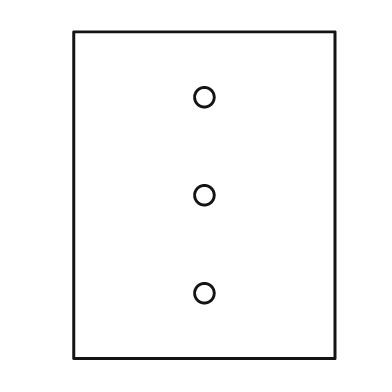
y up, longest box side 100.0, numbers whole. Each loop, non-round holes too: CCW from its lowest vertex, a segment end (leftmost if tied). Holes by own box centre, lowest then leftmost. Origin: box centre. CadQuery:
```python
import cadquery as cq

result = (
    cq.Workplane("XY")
    .moveTo(-40.0, -50.0)
    .lineTo(40.0, -50.0)
    .lineTo(40.0, 50.0)
    .lineTo(-40.0, 50.0)
    .close()
    .moveTo(0.0, -30.0)
    .circle(3.0)
    .moveTo(0.0, 0.0)
    .circle(3.0)
    .moveTo(0.0, 30.0)
    .circle(3.0)
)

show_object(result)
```